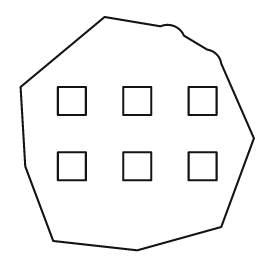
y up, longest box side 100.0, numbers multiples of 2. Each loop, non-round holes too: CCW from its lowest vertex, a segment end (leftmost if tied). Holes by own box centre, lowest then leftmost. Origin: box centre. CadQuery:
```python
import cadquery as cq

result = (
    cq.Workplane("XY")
    .moveTo(0.0, -50.0)
    .lineTo(36.0, -40.0)
    .lineTo(50.0, -2.0)
    .lineTo(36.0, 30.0)
    .threePointArc((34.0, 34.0), (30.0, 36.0))
    .lineTo(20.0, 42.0)
    .threePointArc((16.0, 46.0), (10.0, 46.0))
    .lineTo(-14.0, 50.0)
    .lineTo(-50.0, 20.0)
    .lineTo(-48.0, -14.0)
    .lineTo(-36.0, -46.0)
    .close()
    .moveTo(-34.0, -20.0)
    .lineTo(-22.0, -20.0)
    .lineTo(-22.0, -8.0)
    .lineTo(-34.0, -8.0)
    .close()
    .moveTo(-6.0, -20.0)
    .lineTo(6.0, -20.0)
    .lineTo(6.0, -8.0)
    .lineTo(-6.0, -8.0)
    .close()
    .moveTo(22.0, -20.0)
    .lineTo(34.0, -20.0)
    .lineTo(34.0, -8.0)
    .lineTo(22.0, -8.0)
    .close()
    .moveTo(-34.0, 8.0)
    .lineTo(-22.0, 8.0)
    .lineTo(-22.0, 20.0)
    .lineTo(-34.0, 20.0)
    .close()
    .moveTo(-6.0, 8.0)
    .lineTo(6.0, 8.0)
    .lineTo(6.0, 20.0)
    .lineTo(-6.0, 20.0)
    .close()
    .moveTo(22.0, 8.0)
    .lineTo(34.0, 8.0)
    .lineTo(34.0, 20.0)
    .lineTo(22.0, 20.0)
    .close()
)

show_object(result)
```